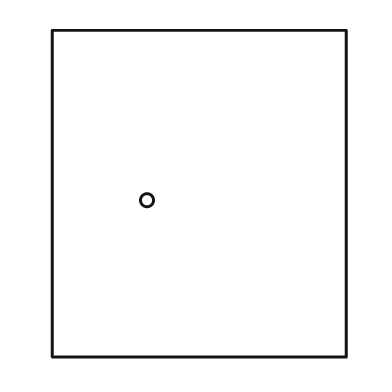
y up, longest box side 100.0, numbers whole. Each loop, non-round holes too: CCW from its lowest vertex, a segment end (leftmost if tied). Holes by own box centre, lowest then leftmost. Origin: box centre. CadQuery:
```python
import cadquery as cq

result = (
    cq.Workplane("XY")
    .moveTo(-45.0, -50.0)
    .lineTo(45.0, -50.0)
    .lineTo(45.0, 50.0)
    .lineTo(-45.0, 50.0)
    .close()
    .moveTo(-16.0, -2.0)
    .circle(2.0)
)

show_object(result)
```